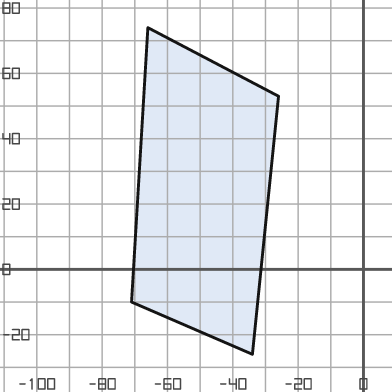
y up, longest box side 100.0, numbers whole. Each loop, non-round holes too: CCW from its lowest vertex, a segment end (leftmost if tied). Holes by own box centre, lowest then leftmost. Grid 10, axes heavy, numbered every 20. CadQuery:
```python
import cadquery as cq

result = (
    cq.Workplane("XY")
    .moveTo(-34.0, -26.0)
    .lineTo(-26.0, 53.0)
    .lineTo(-66.0, 74.0)
    .lineTo(-71.0, -10.0)
    .close()
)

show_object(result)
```